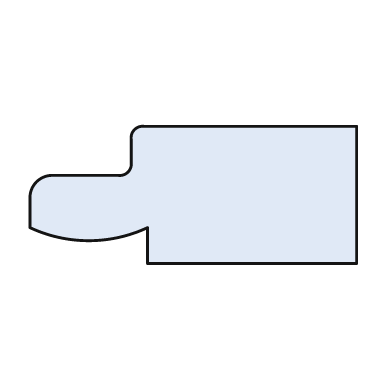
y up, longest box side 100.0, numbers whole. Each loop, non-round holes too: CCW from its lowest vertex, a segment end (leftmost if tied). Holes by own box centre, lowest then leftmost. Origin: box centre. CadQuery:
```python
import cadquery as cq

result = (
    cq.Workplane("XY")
    .moveTo(-14.0, -21.0)
    .lineTo(50.0, -21.0)
    .lineTo(50.0, 21.0)
    .lineTo(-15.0, 21.0)
    .threePointArc((-18.0, 20.0), (-19.0, 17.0))
    .lineTo(-19.0, 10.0)
    .threePointArc((-20.0, 7.0), (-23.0, 6.0))
    .lineTo(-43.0, 6.0)
    .threePointArc((-48.0, 4.0), (-50.0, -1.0))
    .lineTo(-50.0, -10.0)
    .threePointArc((-32.0, -14.0), (-14.0, -10.0))
    .close()
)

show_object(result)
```